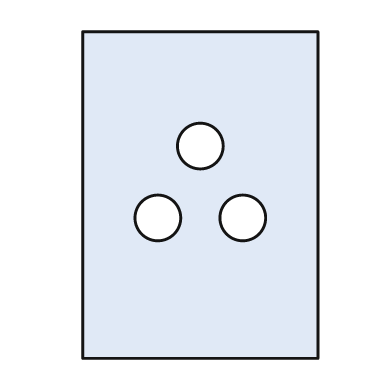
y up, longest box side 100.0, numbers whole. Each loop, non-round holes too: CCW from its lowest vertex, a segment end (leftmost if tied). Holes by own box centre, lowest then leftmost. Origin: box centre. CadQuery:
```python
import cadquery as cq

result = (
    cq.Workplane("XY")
    .moveTo(-36.0, -50.0)
    .lineTo(36.0, -50.0)
    .lineTo(36.0, 50.0)
    .lineTo(-36.0, 50.0)
    .close()
    .moveTo(-13.0, -7.0)
    .circle(7.0)
    .moveTo(13.0, -7.0)
    .circle(7.0)
    .moveTo(0.0, 15.0)
    .circle(7.0)
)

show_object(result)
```